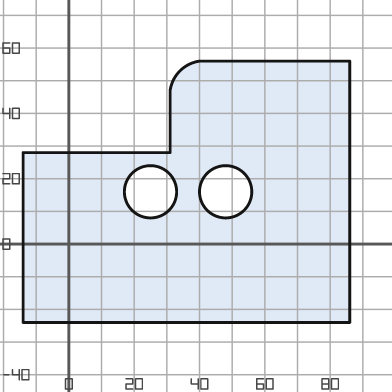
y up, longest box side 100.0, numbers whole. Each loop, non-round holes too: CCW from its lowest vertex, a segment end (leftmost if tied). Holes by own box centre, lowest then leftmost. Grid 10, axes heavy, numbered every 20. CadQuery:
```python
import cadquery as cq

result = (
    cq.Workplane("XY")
    .moveTo(-14.0, -24.0)
    .lineTo(86.0, -24.0)
    .lineTo(86.0, 56.0)
    .lineTo(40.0, 56.0)
    .threePointArc((34.0, 53.0), (31.0, 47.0))
    .lineTo(31.0, 28.0)
    .lineTo(-14.0, 28.0)
    .close()
    .moveTo(25.0, 16.0)
    .circle(8.0)
    .moveTo(48.0, 16.0)
    .circle(8.0)
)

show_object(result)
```